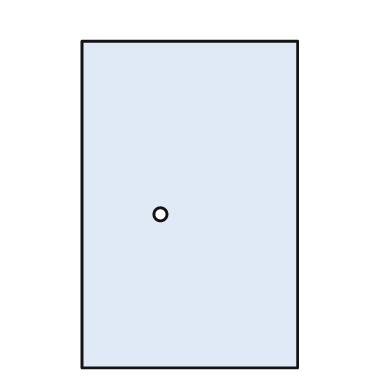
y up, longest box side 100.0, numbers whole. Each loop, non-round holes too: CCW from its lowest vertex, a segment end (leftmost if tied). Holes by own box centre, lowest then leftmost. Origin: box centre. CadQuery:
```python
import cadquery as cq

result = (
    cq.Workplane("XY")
    .moveTo(-33.0, -50.0)
    .lineTo(33.0, -50.0)
    .lineTo(33.0, 50.0)
    .lineTo(-33.0, 50.0)
    .close()
    .moveTo(-9.0, -3.0)
    .circle(2.0)
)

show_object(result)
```